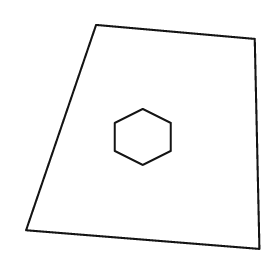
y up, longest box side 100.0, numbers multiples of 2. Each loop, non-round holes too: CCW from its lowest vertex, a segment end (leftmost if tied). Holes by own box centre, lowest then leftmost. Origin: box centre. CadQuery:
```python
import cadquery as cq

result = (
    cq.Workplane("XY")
    .moveTo(50.0, -48.0)
    .lineTo(48.0, 42.0)
    .lineTo(-20.0, 48.0)
    .lineTo(-50.0, -40.0)
    .close()
    .moveTo(0.0, -12.0)
    .lineTo(12.0, -6.0)
    .lineTo(12.0, 6.0)
    .lineTo(0.0, 12.0)
    .lineTo(-12.0, 6.0)
    .lineTo(-12.0, -6.0)
    .close()
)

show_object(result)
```